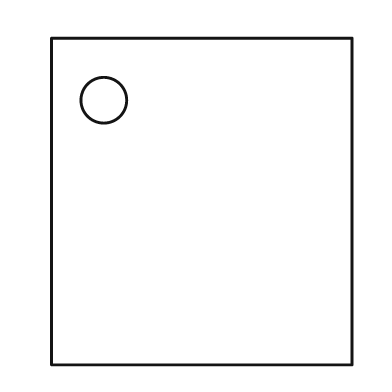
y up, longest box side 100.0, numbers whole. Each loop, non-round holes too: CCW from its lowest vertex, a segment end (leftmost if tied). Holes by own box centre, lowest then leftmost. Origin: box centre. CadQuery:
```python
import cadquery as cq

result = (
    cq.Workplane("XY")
    .moveTo(-46.0, -50.0)
    .lineTo(46.0, -50.0)
    .lineTo(46.0, 50.0)
    .lineTo(-46.0, 50.0)
    .close()
    .moveTo(-30.0, 31.0)
    .circle(7.0)
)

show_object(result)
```